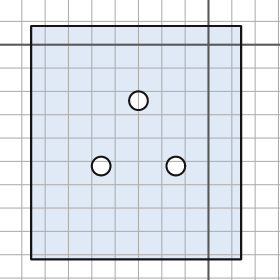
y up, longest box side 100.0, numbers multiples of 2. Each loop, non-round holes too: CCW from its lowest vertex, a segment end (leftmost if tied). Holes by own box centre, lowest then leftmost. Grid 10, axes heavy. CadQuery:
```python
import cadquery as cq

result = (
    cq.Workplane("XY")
    .moveTo(-76.0, -92.0)
    .lineTo(14.0, -92.0)
    .lineTo(14.0, 8.0)
    .lineTo(-76.0, 8.0)
    .close()
    .moveTo(-46.0, -52.0)
    .circle(4.0)
    .moveTo(-14.0, -52.0)
    .circle(4.0)
    .moveTo(-30.0, -24.0)
    .circle(4.0)
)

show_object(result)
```